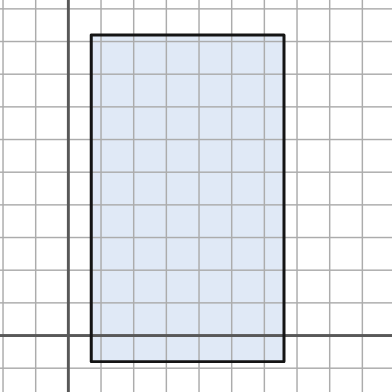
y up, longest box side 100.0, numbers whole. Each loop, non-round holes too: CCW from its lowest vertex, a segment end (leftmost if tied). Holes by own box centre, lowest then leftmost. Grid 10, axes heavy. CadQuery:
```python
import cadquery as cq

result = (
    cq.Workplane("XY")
    .moveTo(7.0, -8.0)
    .lineTo(66.0, -8.0)
    .lineTo(66.0, 92.0)
    .lineTo(7.0, 92.0)
    .close()
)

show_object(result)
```